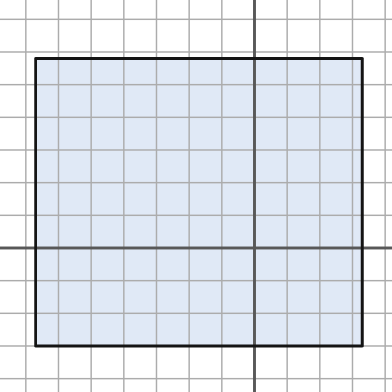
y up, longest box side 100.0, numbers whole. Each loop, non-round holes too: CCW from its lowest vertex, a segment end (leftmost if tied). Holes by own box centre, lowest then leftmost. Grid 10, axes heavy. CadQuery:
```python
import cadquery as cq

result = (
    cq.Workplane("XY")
    .moveTo(-67.0, -30.0)
    .lineTo(33.0, -30.0)
    .lineTo(33.0, 58.0)
    .lineTo(-67.0, 58.0)
    .close()
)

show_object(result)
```